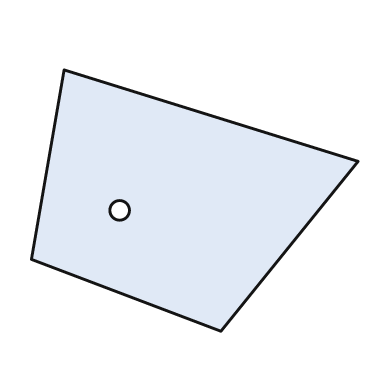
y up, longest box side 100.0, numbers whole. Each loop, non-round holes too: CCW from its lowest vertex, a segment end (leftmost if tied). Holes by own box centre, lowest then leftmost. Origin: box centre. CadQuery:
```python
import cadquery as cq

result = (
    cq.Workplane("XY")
    .moveTo(8.0, -40.0)
    .lineTo(50.0, 12.0)
    .lineTo(-40.0, 40.0)
    .lineTo(-50.0, -18.0)
    .close()
    .moveTo(-23.0, -3.0)
    .circle(3.0)
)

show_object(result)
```